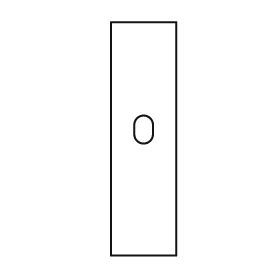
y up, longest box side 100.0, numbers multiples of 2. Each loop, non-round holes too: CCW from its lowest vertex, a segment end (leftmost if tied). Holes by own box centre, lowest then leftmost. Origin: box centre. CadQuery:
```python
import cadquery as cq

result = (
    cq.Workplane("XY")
    .moveTo(-14.0, -50.0)
    .lineTo(14.0, -50.0)
    .lineTo(14.0, 50.0)
    .lineTo(-14.0, 50.0)
    .close()
    .moveTo(-4.0, 2.0)
    .threePointArc((0.0, -2.0), (4.0, 2.0))
    .lineTo(4.0, 6.0)
    .threePointArc((0.0, 10.0), (-4.0, 6.0))
    .close()
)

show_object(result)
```